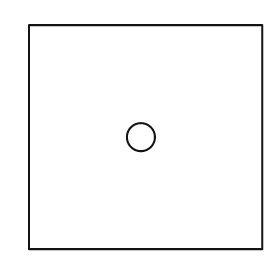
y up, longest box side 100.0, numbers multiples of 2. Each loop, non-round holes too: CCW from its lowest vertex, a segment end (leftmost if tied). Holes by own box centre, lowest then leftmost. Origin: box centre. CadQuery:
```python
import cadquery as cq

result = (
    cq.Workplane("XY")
    .moveTo(-50.0, -48.0)
    .lineTo(50.0, -48.0)
    .lineTo(50.0, 48.0)
    .lineTo(-50.0, 48.0)
    .close()
    .moveTo(-2.0, 0.0)
    .circle(6.0)
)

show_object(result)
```